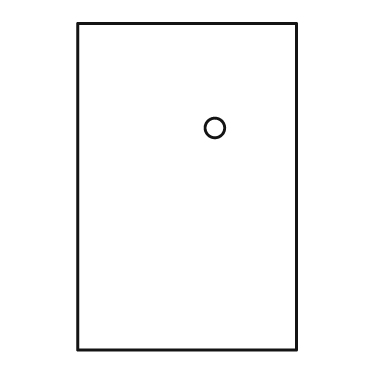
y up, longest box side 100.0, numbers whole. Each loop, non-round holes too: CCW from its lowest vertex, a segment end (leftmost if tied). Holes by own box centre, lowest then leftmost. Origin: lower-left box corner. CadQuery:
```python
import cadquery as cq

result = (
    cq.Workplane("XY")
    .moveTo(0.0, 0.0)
    .lineTo(67.0, 0.0)
    .lineTo(67.0, 100.0)
    .lineTo(0.0, 100.0)
    .close()
    .moveTo(42.0, 68.0)
    .circle(3.0)
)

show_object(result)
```